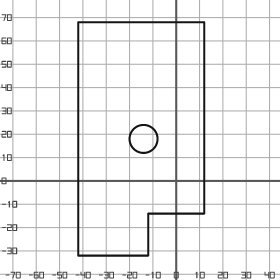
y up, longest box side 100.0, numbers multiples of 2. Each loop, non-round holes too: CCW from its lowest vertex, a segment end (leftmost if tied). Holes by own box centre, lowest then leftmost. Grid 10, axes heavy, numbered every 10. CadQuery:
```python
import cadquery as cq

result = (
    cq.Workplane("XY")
    .moveTo(-42.0, -32.0)
    .lineTo(-12.0, -32.0)
    .lineTo(-12.0, -14.0)
    .lineTo(12.0, -14.0)
    .lineTo(12.0, 68.0)
    .lineTo(-42.0, 68.0)
    .close()
    .moveTo(-14.0, 18.0)
    .circle(6.0)
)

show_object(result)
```